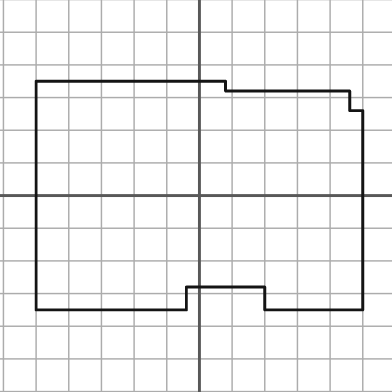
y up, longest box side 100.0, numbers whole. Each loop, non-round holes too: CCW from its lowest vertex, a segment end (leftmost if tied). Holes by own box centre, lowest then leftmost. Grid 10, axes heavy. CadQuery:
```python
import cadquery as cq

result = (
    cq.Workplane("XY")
    .moveTo(-50.0, -35.0)
    .lineTo(-4.0, -35.0)
    .lineTo(-4.0, -28.0)
    .lineTo(20.0, -28.0)
    .lineTo(20.0, -35.0)
    .lineTo(50.0, -35.0)
    .lineTo(50.0, 26.0)
    .lineTo(46.0, 26.0)
    .lineTo(46.0, 32.0)
    .lineTo(8.0, 32.0)
    .lineTo(8.0, 35.0)
    .lineTo(-50.0, 35.0)
    .close()
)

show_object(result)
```